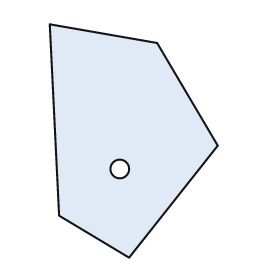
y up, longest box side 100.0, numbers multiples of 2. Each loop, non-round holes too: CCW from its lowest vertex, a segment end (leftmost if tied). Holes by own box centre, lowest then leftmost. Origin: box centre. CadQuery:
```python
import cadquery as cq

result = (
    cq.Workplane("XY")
    .moveTo(-2.0, -50.0)
    .lineTo(36.0, -2.0)
    .lineTo(10.0, 42.0)
    .lineTo(-36.0, 50.0)
    .lineTo(-32.0, -32.0)
    .close()
    .moveTo(-6.0, -12.0)
    .circle(4.0)
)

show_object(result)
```